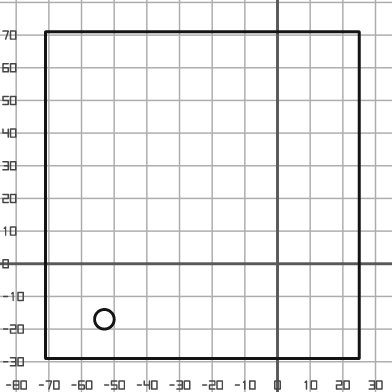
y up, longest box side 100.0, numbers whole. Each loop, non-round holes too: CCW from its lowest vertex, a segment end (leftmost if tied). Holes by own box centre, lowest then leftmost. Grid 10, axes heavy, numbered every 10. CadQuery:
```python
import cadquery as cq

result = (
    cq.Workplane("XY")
    .moveTo(-71.0, -29.0)
    .lineTo(25.0, -29.0)
    .lineTo(25.0, 71.0)
    .lineTo(-71.0, 71.0)
    .close()
    .moveTo(-53.0, -17.0)
    .circle(3.0)
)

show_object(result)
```